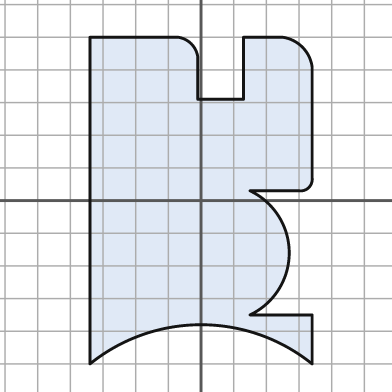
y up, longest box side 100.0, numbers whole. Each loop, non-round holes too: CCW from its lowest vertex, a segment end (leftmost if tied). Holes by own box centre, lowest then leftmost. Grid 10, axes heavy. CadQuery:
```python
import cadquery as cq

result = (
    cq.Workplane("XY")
    .moveTo(-34.0, -50.0)
    .threePointArc((0.0, -38.0), (34.0, -50.0))
    .lineTo(34.0, -35.0)
    .lineTo(15.0, -35.0)
    .threePointArc((27.0, -16.0), (15.0, 3.0))
    .lineTo(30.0, 3.0)
    .threePointArc((33.0, 4.0), (34.0, 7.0))
    .lineTo(34.0, 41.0)
    .threePointArc((31.0, 47.0), (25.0, 50.0))
    .lineTo(13.0, 50.0)
    .lineTo(13.0, 31.0)
    .lineTo(-1.0, 31.0)
    .lineTo(-1.0, 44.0)
    .threePointArc((-3.0, 48.0), (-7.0, 50.0))
    .lineTo(-34.0, 50.0)
    .close()
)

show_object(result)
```